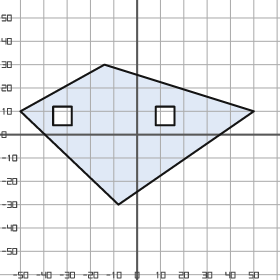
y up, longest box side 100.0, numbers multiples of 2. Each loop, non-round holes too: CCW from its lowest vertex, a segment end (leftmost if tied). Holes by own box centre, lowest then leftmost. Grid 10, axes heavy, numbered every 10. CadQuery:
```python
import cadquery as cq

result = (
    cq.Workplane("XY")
    .moveTo(-8.0, -30.0)
    .lineTo(50.0, 10.0)
    .lineTo(-14.0, 30.0)
    .lineTo(-50.0, 10.0)
    .close()
    .moveTo(-36.0, 4.0)
    .lineTo(-28.0, 4.0)
    .lineTo(-28.0, 12.0)
    .lineTo(-36.0, 12.0)
    .close()
    .moveTo(8.0, 4.0)
    .lineTo(16.0, 4.0)
    .lineTo(16.0, 12.0)
    .lineTo(8.0, 12.0)
    .close()
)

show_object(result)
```